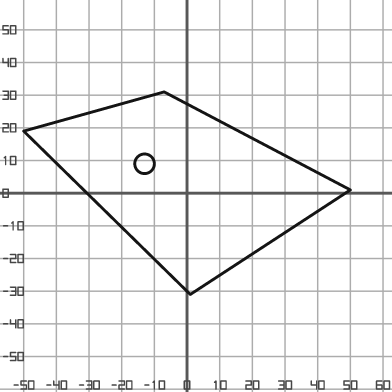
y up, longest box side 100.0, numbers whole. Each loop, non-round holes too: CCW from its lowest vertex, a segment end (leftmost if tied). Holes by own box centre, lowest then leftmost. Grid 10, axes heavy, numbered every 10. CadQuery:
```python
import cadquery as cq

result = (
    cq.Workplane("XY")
    .moveTo(1.0, -31.0)
    .lineTo(50.0, 1.0)
    .lineTo(-7.0, 31.0)
    .lineTo(-50.0, 19.0)
    .close()
    .moveTo(-13.0, 9.0)
    .circle(3.0)
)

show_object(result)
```